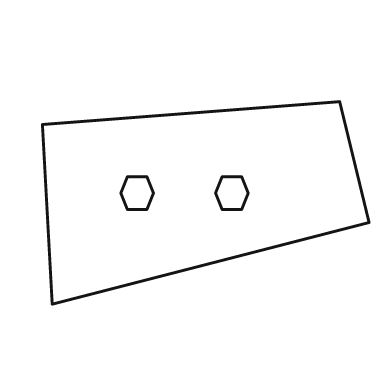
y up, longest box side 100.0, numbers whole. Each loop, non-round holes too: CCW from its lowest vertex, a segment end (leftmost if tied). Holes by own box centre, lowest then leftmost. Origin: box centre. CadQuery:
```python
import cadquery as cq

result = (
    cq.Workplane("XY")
    .moveTo(-47.0, -31.0)
    .lineTo(50.0, -6.0)
    .lineTo(41.0, 31.0)
    .lineTo(-50.0, 24.0)
    .close()
    .moveTo(-24.0, -2.0)
    .lineTo(-18.0, -2.0)
    .lineTo(-16.0, 3.0)
    .lineTo(-18.0, 8.0)
    .lineTo(-24.0, 8.0)
    .lineTo(-26.0, 3.0)
    .close()
    .moveTo(5.0, -2.0)
    .lineTo(11.0, -2.0)
    .lineTo(13.0, 3.0)
    .lineTo(11.0, 8.0)
    .lineTo(5.0, 8.0)
    .lineTo(3.0, 3.0)
    .close()
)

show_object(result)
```